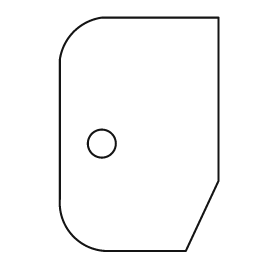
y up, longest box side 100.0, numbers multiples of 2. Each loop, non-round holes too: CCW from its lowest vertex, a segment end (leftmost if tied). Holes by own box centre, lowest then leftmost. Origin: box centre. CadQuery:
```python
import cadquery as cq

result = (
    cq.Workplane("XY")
    .moveTo(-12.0, -50.0)
    .lineTo(20.0, -50.0)
    .lineTo(34.0, -20.0)
    .lineTo(34.0, 50.0)
    .lineTo(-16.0, 50.0)
    .threePointArc((-28.0, 44.0), (-34.0, 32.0))
    .lineTo(-34.0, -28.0)
    .threePointArc((-28.0, -44.0), (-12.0, -50.0))
    .close()
    .moveTo(-16.0, -4.0)
    .circle(6.0)
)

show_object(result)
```